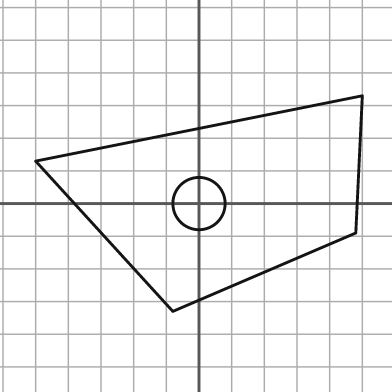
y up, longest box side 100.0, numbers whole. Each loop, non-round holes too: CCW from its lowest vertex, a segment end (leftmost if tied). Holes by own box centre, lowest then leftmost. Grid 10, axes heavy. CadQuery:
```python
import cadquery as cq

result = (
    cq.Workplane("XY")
    .moveTo(-8.0, -33.0)
    .lineTo(48.0, -9.0)
    .lineTo(50.0, 33.0)
    .lineTo(-50.0, 13.0)
    .close()
    .moveTo(0.0, 0.0)
    .circle(8.0)
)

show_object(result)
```